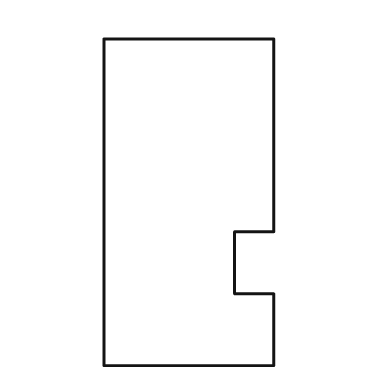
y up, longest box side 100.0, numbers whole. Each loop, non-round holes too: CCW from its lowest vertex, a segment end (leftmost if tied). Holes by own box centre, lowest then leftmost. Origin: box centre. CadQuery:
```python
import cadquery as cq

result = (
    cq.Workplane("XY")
    .moveTo(-26.0, -50.0)
    .lineTo(26.0, -50.0)
    .lineTo(26.0, -28.0)
    .lineTo(14.0, -28.0)
    .lineTo(14.0, -9.0)
    .lineTo(26.0, -9.0)
    .lineTo(26.0, 50.0)
    .lineTo(-26.0, 50.0)
    .close()
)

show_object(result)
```